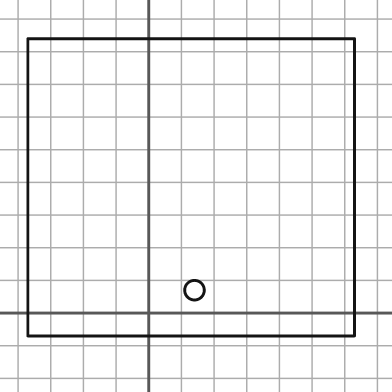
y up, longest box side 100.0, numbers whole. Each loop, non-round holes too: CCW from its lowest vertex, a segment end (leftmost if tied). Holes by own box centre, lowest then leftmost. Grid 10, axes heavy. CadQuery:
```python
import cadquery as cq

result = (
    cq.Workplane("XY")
    .moveTo(-37.0, -7.0)
    .lineTo(63.0, -7.0)
    .lineTo(63.0, 84.0)
    .lineTo(-37.0, 84.0)
    .close()
    .moveTo(14.0, 7.0)
    .circle(3.0)
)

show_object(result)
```